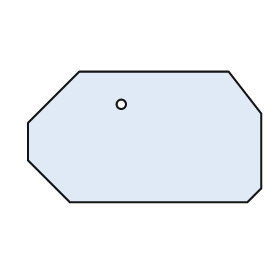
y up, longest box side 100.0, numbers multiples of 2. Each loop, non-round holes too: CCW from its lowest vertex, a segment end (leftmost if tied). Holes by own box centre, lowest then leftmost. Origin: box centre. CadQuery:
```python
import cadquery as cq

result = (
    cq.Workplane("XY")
    .moveTo(-32.0, -28.0)
    .lineTo(44.0, -28.0)
    .lineTo(50.0, -22.0)
    .lineTo(50.0, 10.0)
    .lineTo(36.0, 28.0)
    .lineTo(-28.0, 28.0)
    .lineTo(-50.0, 6.0)
    .lineTo(-50.0, -10.0)
    .close()
    .moveTo(-10.0, 14.0)
    .circle(2.0)
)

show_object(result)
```